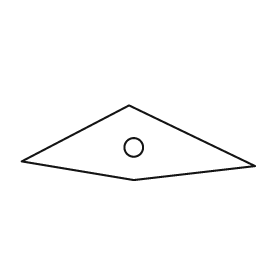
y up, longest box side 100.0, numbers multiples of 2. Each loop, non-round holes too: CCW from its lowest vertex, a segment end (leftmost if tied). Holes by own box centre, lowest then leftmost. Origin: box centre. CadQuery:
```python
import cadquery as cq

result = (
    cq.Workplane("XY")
    .moveTo(-2.0, -16.0)
    .lineTo(50.0, -10.0)
    .lineTo(-4.0, 16.0)
    .lineTo(-50.0, -8.0)
    .close()
    .moveTo(-2.0, -2.0)
    .circle(4.0)
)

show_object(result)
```